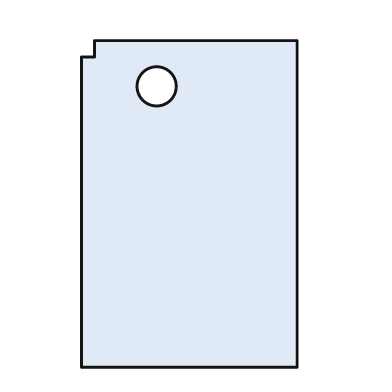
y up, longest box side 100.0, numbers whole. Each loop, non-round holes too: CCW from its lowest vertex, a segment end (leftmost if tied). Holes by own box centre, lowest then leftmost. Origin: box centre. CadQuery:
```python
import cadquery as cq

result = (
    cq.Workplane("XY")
    .moveTo(-33.0, -50.0)
    .lineTo(33.0, -50.0)
    .lineTo(33.0, 50.0)
    .lineTo(-29.0, 50.0)
    .lineTo(-29.0, 45.0)
    .lineTo(-33.0, 45.0)
    .close()
    .moveTo(-10.0, 36.0)
    .circle(6.0)
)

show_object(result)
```